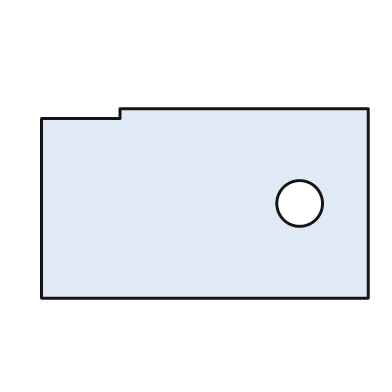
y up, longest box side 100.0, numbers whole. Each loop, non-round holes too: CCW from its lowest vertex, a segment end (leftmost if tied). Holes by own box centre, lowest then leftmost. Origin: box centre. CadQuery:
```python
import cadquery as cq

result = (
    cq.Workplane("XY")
    .moveTo(-50.0, -29.0)
    .lineTo(50.0, -29.0)
    .lineTo(50.0, 29.0)
    .lineTo(-26.0, 29.0)
    .lineTo(-26.0, 26.0)
    .lineTo(-50.0, 26.0)
    .close()
    .moveTo(29.0, 0.0)
    .circle(7.0)
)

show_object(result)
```